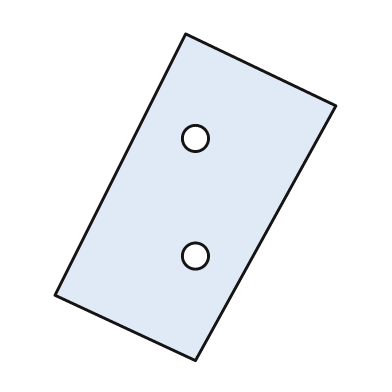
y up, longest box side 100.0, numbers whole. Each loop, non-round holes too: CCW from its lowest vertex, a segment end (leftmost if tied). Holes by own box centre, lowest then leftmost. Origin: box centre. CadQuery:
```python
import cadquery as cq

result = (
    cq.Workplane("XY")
    .moveTo(0.0, -50.0)
    .lineTo(43.0, 28.0)
    .lineTo(-3.0, 50.0)
    .lineTo(-43.0, -30.0)
    .close()
    .moveTo(0.0, -18.0)
    .circle(4.0)
    .moveTo(0.0, 18.0)
    .circle(4.0)
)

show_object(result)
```